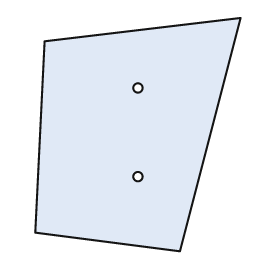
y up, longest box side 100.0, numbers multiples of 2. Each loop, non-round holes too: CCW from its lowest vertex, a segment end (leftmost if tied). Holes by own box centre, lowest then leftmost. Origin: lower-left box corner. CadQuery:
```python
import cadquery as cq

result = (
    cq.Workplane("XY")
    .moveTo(62.0, 0.0)
    .lineTo(88.0, 100.0)
    .lineTo(4.0, 90.0)
    .lineTo(0.0, 8.0)
    .close()
    .moveTo(44.0, 32.0)
    .circle(2.0)
    .moveTo(44.0, 70.0)
    .circle(2.0)
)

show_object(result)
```